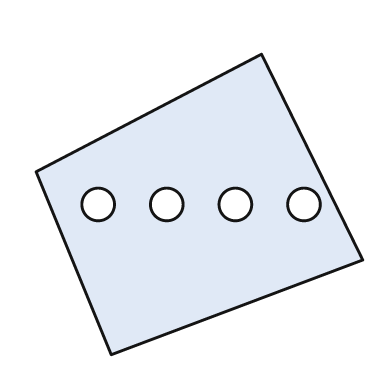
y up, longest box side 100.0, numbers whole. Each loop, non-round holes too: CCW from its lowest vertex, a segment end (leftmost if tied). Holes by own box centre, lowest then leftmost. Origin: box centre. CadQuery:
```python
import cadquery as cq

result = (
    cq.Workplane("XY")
    .moveTo(-27.0, -46.0)
    .lineTo(50.0, -17.0)
    .lineTo(19.0, 46.0)
    .lineTo(-50.0, 10.0)
    .close()
    .moveTo(-31.0, 0.0)
    .circle(5.0)
    .moveTo(-10.0, 0.0)
    .circle(5.0)
    .moveTo(11.0, 0.0)
    .circle(5.0)
    .moveTo(32.0, 0.0)
    .circle(5.0)
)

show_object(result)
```